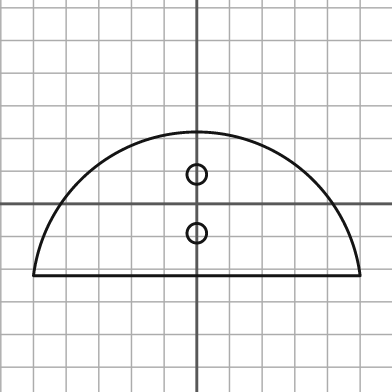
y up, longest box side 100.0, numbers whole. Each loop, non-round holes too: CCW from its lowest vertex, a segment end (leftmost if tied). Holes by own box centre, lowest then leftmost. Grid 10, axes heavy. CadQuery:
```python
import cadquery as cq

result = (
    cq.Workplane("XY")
    .moveTo(-50.0, -22.0)
    .lineTo(50.0, -22.0)
    .threePointArc((0.0, 22.0), (-50.0, -22.0))
    .close()
    .moveTo(0.0, -9.0)
    .circle(3.0)
    .moveTo(0.0, 9.0)
    .circle(3.0)
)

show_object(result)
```